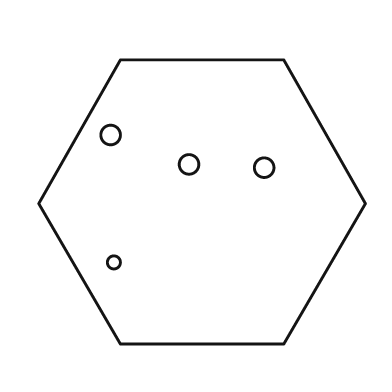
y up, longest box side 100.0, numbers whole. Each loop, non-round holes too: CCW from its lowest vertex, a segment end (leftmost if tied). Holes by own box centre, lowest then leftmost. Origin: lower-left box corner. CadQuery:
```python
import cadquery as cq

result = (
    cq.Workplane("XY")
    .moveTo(25.0, 0.0)
    .lineTo(75.0, 0.0)
    .lineTo(100.0, 43.0)
    .lineTo(75.0, 87.0)
    .lineTo(25.0, 87.0)
    .lineTo(0.0, 43.0)
    .close()
    .moveTo(23.0, 25.0)
    .circle(2.0)
    .moveTo(69.0, 54.0)
    .circle(3.0)
    .moveTo(46.0, 55.0)
    .circle(3.0)
    .moveTo(22.0, 64.0)
    .circle(3.0)
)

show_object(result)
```